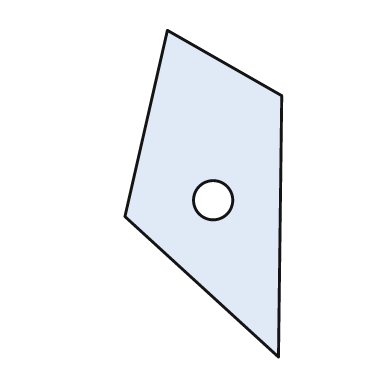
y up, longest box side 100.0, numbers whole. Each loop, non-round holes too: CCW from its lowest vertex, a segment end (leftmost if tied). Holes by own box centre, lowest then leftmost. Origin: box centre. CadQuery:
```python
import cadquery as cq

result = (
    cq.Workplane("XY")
    .moveTo(23.0, -50.0)
    .lineTo(24.0, 30.0)
    .lineTo(-11.0, 50.0)
    .lineTo(-24.0, -7.0)
    .close()
    .moveTo(3.0, -2.0)
    .circle(6.0)
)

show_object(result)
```